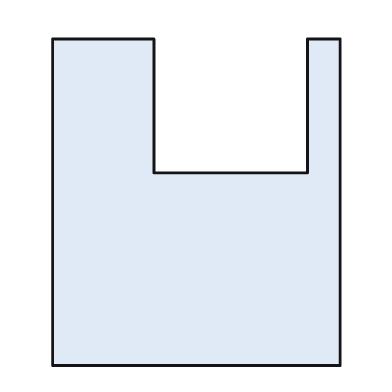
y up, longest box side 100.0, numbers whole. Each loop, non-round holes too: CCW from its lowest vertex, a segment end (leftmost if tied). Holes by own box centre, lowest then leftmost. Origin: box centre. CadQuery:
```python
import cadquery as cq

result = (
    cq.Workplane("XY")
    .moveTo(-44.0, -50.0)
    .lineTo(44.0, -50.0)
    .lineTo(44.0, 50.0)
    .lineTo(34.0, 50.0)
    .lineTo(34.0, 9.0)
    .lineTo(-13.0, 9.0)
    .lineTo(-13.0, 50.0)
    .lineTo(-44.0, 50.0)
    .close()
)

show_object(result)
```